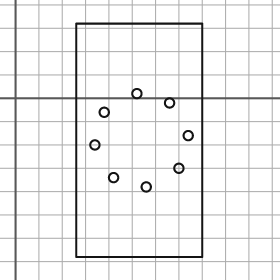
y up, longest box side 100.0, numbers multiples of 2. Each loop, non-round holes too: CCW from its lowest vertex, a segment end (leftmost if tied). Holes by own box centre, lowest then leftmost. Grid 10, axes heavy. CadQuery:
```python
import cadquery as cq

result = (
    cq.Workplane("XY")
    .moveTo(26.0, -68.0)
    .lineTo(80.0, -68.0)
    .lineTo(80.0, 32.0)
    .lineTo(26.0, 32.0)
    .close()
    .moveTo(56.0, -38.0)
    .circle(2.0)
    .moveTo(42.0, -34.0)
    .circle(2.0)
    .moveTo(70.0, -30.0)
    .circle(2.0)
    .moveTo(34.0, -20.0)
    .circle(2.0)
    .moveTo(74.0, -16.0)
    .circle(2.0)
    .moveTo(38.0, -6.0)
    .circle(2.0)
    .moveTo(66.0, -2.0)
    .circle(2.0)
    .moveTo(52.0, 2.0)
    .circle(2.0)
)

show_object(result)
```